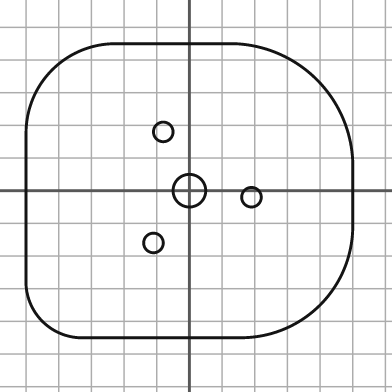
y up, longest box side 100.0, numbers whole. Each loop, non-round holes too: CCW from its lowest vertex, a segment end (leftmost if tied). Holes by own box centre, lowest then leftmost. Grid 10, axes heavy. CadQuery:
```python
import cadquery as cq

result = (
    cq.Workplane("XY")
    .moveTo(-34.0, -45.0)
    .lineTo(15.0, -45.0)
    .threePointArc((40.0, -35.0), (50.0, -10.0))
    .lineTo(50.0, 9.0)
    .threePointArc((39.0, 34.0), (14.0, 45.0))
    .lineTo(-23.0, 45.0)
    .threePointArc((-42.0, 37.0), (-50.0, 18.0))
    .lineTo(-50.0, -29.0)
    .threePointArc((-45.0, -40.0), (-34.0, -45.0))
    .close()
    .moveTo(-11.0, -16.0)
    .circle(3.0)
    .moveTo(19.0, -2.0)
    .circle(3.0)
    .moveTo(0.0, 0.0)
    .circle(5.0)
    .moveTo(-8.0, 18.0)
    .circle(3.0)
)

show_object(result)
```